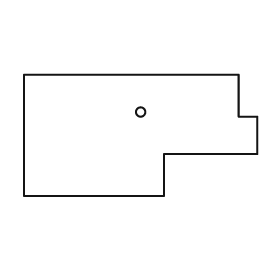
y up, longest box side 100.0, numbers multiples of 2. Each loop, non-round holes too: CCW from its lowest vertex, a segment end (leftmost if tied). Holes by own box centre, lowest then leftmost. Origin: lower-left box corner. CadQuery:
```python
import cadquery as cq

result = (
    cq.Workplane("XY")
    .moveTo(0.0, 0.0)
    .lineTo(60.0, 0.0)
    .lineTo(60.0, 18.0)
    .lineTo(100.0, 18.0)
    .lineTo(100.0, 34.0)
    .lineTo(92.0, 34.0)
    .lineTo(92.0, 52.0)
    .lineTo(0.0, 52.0)
    .close()
    .moveTo(50.0, 36.0)
    .circle(2.0)
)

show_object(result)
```